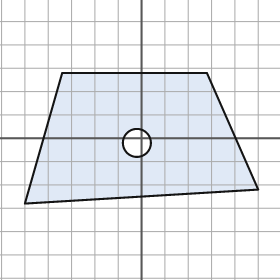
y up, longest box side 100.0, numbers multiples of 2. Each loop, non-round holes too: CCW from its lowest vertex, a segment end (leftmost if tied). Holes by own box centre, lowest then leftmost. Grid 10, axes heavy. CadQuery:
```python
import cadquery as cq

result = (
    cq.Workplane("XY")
    .moveTo(-50.0, -28.0)
    .lineTo(50.0, -22.0)
    .lineTo(28.0, 28.0)
    .lineTo(-34.0, 28.0)
    .close()
    .moveTo(-2.0, -2.0)
    .circle(6.0)
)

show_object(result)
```